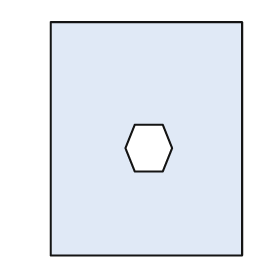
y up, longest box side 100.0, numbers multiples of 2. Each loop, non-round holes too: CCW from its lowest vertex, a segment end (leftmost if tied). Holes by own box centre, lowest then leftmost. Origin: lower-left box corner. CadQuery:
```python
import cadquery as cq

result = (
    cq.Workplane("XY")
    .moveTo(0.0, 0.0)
    .lineTo(82.0, 0.0)
    .lineTo(82.0, 100.0)
    .lineTo(0.0, 100.0)
    .close()
    .moveTo(36.0, 36.0)
    .lineTo(48.0, 36.0)
    .lineTo(52.0, 46.0)
    .lineTo(48.0, 56.0)
    .lineTo(36.0, 56.0)
    .lineTo(32.0, 46.0)
    .close()
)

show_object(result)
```